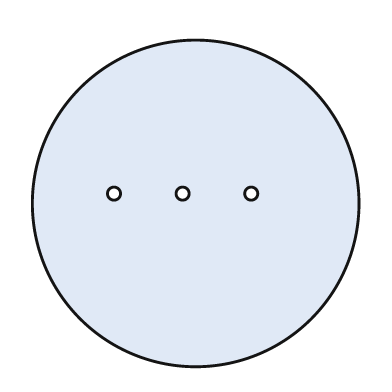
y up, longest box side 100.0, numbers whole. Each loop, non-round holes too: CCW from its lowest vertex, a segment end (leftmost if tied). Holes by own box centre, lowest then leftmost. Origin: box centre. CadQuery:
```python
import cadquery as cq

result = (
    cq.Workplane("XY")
    .moveTo(0.0, 0.0)
    .circle(50.0)
    .moveTo(-25.0, 3.0)
    .circle(2.0)
    .moveTo(-4.0, 3.0)
    .circle(2.0)
    .moveTo(17.0, 3.0)
    .circle(2.0)
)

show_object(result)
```